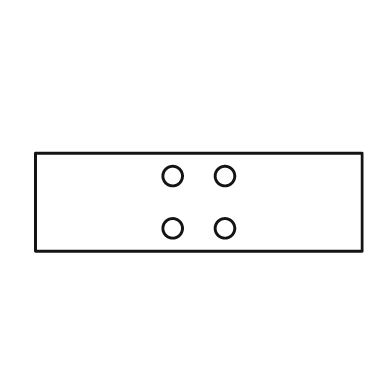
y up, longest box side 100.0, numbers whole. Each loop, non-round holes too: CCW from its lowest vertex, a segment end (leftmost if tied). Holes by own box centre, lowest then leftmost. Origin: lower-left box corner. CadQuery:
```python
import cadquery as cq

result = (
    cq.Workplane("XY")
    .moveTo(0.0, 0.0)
    .lineTo(100.0, 0.0)
    .lineTo(100.0, 30.0)
    .lineTo(0.0, 30.0)
    .close()
    .moveTo(42.0, 7.0)
    .circle(3.0)
    .moveTo(58.0, 7.0)
    .circle(3.0)
    .moveTo(42.0, 23.0)
    .circle(3.0)
    .moveTo(58.0, 23.0)
    .circle(3.0)
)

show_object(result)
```